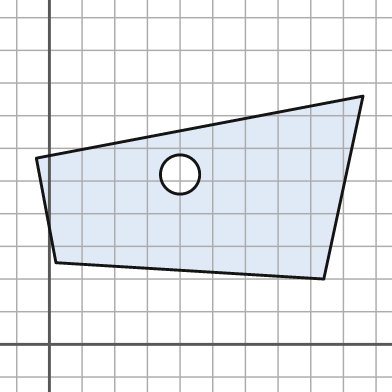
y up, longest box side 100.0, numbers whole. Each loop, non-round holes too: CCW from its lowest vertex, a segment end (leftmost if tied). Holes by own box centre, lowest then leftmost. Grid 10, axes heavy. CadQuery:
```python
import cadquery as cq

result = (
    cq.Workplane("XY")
    .moveTo(84.0, 20.0)
    .lineTo(96.0, 76.0)
    .lineTo(-4.0, 57.0)
    .lineTo(2.0, 25.0)
    .close()
    .moveTo(40.0, 52.0)
    .circle(6.0)
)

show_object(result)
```